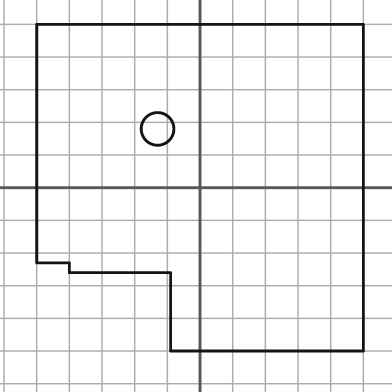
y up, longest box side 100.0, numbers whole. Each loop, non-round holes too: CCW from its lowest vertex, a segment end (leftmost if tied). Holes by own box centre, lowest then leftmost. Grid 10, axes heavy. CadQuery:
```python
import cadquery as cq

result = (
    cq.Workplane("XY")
    .moveTo(-9.0, -50.0)
    .lineTo(50.0, -50.0)
    .lineTo(50.0, 50.0)
    .lineTo(-50.0, 50.0)
    .lineTo(-50.0, -23.0)
    .lineTo(-40.0, -23.0)
    .lineTo(-40.0, -26.0)
    .lineTo(-9.0, -26.0)
    .close()
    .moveTo(-13.0, 18.0)
    .circle(5.0)
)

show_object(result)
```